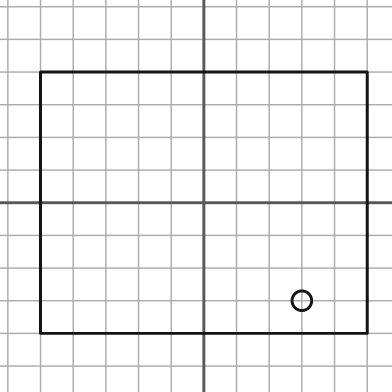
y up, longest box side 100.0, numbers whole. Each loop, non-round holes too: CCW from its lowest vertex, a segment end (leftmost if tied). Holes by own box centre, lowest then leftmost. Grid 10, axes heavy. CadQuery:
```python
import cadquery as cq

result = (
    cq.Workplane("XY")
    .moveTo(-50.0, -40.0)
    .lineTo(50.0, -40.0)
    .lineTo(50.0, 40.0)
    .lineTo(-50.0, 40.0)
    .close()
    .moveTo(30.0, -30.0)
    .circle(3.0)
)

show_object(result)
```